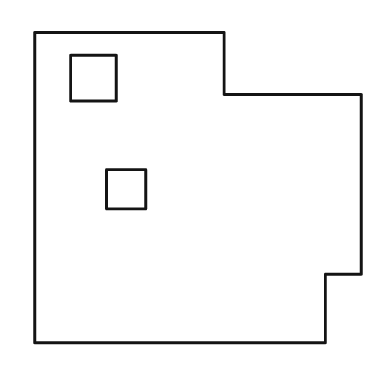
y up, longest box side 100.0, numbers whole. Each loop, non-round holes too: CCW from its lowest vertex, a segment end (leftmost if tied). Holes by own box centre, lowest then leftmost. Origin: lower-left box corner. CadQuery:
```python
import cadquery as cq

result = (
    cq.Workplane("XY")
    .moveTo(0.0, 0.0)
    .lineTo(89.0, 0.0)
    .lineTo(89.0, 21.0)
    .lineTo(100.0, 21.0)
    .lineTo(100.0, 76.0)
    .lineTo(58.0, 76.0)
    .lineTo(58.0, 95.0)
    .lineTo(0.0, 95.0)
    .close()
    .moveTo(22.0, 41.0)
    .lineTo(34.0, 41.0)
    .lineTo(34.0, 53.0)
    .lineTo(22.0, 53.0)
    .close()
    .moveTo(11.0, 74.0)
    .lineTo(25.0, 74.0)
    .lineTo(25.0, 88.0)
    .lineTo(11.0, 88.0)
    .close()
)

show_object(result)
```